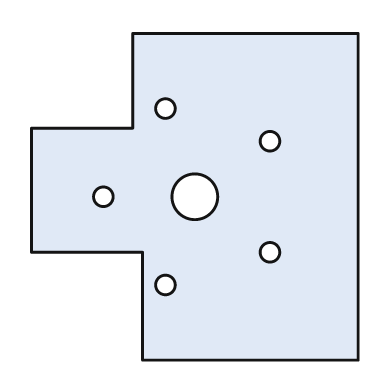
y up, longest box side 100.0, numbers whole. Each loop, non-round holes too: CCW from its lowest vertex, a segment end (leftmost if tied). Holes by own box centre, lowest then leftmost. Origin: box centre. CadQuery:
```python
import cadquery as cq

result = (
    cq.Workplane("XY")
    .moveTo(-16.0, -50.0)
    .lineTo(50.0, -50.0)
    .lineTo(50.0, 50.0)
    .lineTo(-19.0, 50.0)
    .lineTo(-19.0, 21.0)
    .lineTo(-50.0, 21.0)
    .lineTo(-50.0, -17.0)
    .lineTo(-16.0, -17.0)
    .close()
    .moveTo(-9.0, -27.0)
    .circle(3.0)
    .moveTo(23.0, -17.0)
    .circle(3.0)
    .moveTo(-28.0, 0.0)
    .circle(3.0)
    .moveTo(0.0, 0.0)
    .circle(7.0)
    .moveTo(23.0, 17.0)
    .circle(3.0)
    .moveTo(-9.0, 27.0)
    .circle(3.0)
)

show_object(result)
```